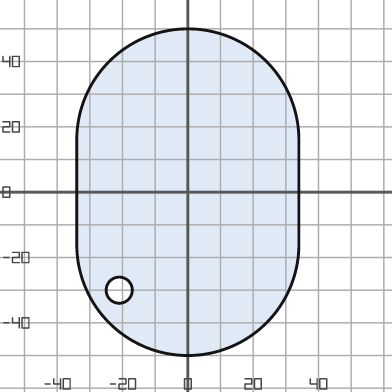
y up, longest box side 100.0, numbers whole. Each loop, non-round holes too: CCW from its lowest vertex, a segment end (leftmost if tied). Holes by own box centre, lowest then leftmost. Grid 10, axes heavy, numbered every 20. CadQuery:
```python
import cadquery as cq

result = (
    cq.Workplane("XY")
    .moveTo(-34.0, -16.0)
    .threePointArc((0.0, -50.0), (34.0, -16.0))
    .lineTo(34.0, 16.0)
    .threePointArc((0.0, 50.0), (-34.0, 16.0))
    .close()
    .moveTo(-21.0, -30.0)
    .circle(4.0)
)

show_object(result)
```